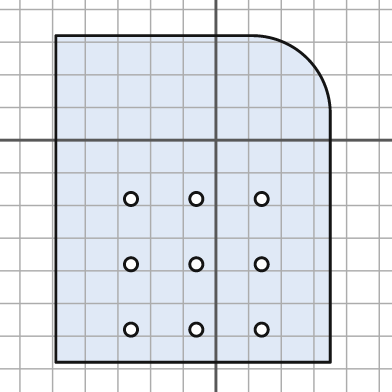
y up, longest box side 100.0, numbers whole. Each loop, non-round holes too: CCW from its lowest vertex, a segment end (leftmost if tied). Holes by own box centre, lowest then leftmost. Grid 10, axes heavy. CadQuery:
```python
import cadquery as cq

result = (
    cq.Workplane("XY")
    .moveTo(-49.0, -68.0)
    .lineTo(35.0, -68.0)
    .lineTo(35.0, 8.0)
    .threePointArc((28.0, 25.0), (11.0, 32.0))
    .lineTo(-49.0, 32.0)
    .close()
    .moveTo(-26.0, -58.0)
    .circle(2.0)
    .moveTo(-6.0, -58.0)
    .circle(2.0)
    .moveTo(14.0, -58.0)
    .circle(2.0)
    .moveTo(-26.0, -38.0)
    .circle(2.0)
    .moveTo(-6.0, -38.0)
    .circle(2.0)
    .moveTo(14.0, -38.0)
    .circle(2.0)
    .moveTo(-26.0, -18.0)
    .circle(2.0)
    .moveTo(-6.0, -18.0)
    .circle(2.0)
    .moveTo(14.0, -18.0)
    .circle(2.0)
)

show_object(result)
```